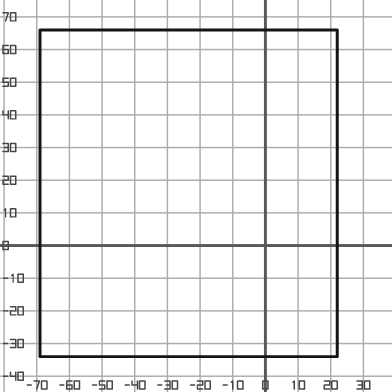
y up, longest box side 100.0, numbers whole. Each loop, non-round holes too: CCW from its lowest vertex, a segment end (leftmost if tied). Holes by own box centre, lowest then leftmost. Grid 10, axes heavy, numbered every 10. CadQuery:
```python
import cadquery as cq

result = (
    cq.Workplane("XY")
    .moveTo(-69.0, -34.0)
    .lineTo(22.0, -34.0)
    .lineTo(22.0, 66.0)
    .lineTo(-69.0, 66.0)
    .close()
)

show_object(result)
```